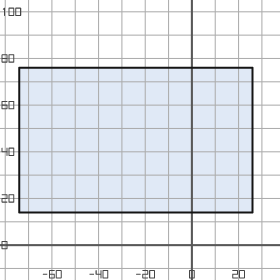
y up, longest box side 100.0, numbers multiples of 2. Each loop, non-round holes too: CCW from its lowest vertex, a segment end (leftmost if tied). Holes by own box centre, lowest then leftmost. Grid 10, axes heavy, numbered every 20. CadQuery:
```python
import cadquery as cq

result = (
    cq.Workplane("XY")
    .moveTo(-74.0, 14.0)
    .lineTo(26.0, 14.0)
    .lineTo(26.0, 76.0)
    .lineTo(-74.0, 76.0)
    .close()
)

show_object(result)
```